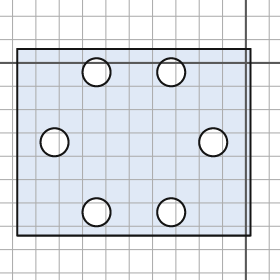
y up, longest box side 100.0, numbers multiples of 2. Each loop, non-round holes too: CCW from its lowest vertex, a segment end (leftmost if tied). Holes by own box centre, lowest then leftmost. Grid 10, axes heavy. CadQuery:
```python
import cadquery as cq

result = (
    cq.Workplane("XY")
    .moveTo(-98.0, -74.0)
    .lineTo(2.0, -74.0)
    .lineTo(2.0, 6.0)
    .lineTo(-98.0, 6.0)
    .close()
    .moveTo(-64.0, -64.0)
    .circle(6.0)
    .moveTo(-32.0, -64.0)
    .circle(6.0)
    .moveTo(-82.0, -34.0)
    .circle(6.0)
    .moveTo(-14.0, -34.0)
    .circle(6.0)
    .moveTo(-64.0, -4.0)
    .circle(6.0)
    .moveTo(-32.0, -4.0)
    .circle(6.0)
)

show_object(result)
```